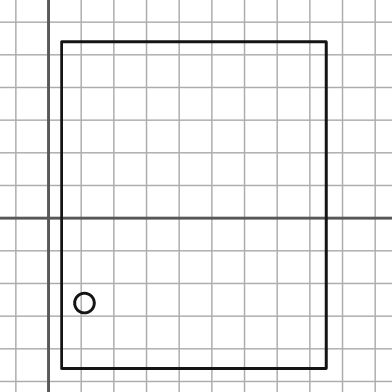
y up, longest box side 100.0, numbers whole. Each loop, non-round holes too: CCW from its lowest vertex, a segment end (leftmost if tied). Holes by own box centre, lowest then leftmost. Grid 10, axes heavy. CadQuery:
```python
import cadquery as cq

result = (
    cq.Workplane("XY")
    .moveTo(4.0, -46.0)
    .lineTo(85.0, -46.0)
    .lineTo(85.0, 54.0)
    .lineTo(4.0, 54.0)
    .close()
    .moveTo(11.0, -26.0)
    .circle(3.0)
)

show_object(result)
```